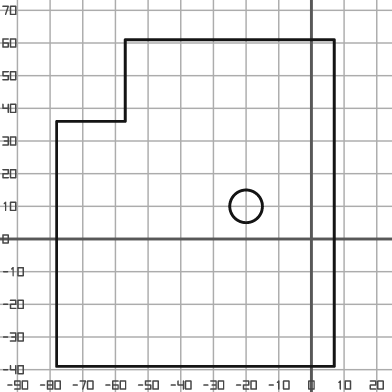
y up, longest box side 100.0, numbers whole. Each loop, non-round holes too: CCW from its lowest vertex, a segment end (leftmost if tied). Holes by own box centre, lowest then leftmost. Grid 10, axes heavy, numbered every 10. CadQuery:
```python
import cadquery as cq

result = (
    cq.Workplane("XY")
    .moveTo(-78.0, -39.0)
    .lineTo(7.0, -39.0)
    .lineTo(7.0, 61.0)
    .lineTo(-57.0, 61.0)
    .lineTo(-57.0, 36.0)
    .lineTo(-78.0, 36.0)
    .close()
    .moveTo(-20.0, 10.0)
    .circle(5.0)
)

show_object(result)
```